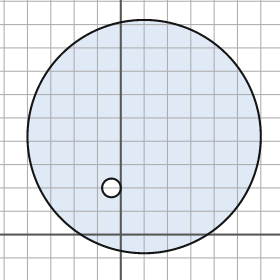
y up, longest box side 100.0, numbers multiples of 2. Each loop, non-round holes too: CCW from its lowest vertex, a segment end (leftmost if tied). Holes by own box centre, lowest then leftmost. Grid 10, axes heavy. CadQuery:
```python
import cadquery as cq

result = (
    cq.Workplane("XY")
    .moveTo(10.0, 42.0)
    .circle(50.0)
    .moveTo(-4.0, 20.0)
    .circle(4.0)
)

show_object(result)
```